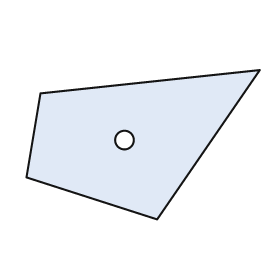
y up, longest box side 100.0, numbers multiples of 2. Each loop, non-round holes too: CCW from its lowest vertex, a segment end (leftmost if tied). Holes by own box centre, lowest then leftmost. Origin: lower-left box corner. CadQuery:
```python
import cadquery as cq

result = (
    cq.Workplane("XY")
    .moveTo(56.0, 0.0)
    .lineTo(100.0, 64.0)
    .lineTo(6.0, 54.0)
    .lineTo(0.0, 18.0)
    .close()
    .moveTo(42.0, 34.0)
    .circle(4.0)
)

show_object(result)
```